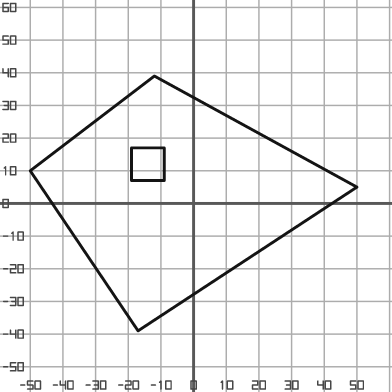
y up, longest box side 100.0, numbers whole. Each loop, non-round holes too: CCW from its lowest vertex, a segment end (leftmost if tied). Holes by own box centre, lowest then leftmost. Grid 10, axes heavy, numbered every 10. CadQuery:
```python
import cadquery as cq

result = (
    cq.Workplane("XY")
    .moveTo(-17.0, -39.0)
    .lineTo(50.0, 5.0)
    .lineTo(-12.0, 39.0)
    .lineTo(-50.0, 10.0)
    .close()
    .moveTo(-19.0, 7.0)
    .lineTo(-9.0, 7.0)
    .lineTo(-9.0, 17.0)
    .lineTo(-19.0, 17.0)
    .close()
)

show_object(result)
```